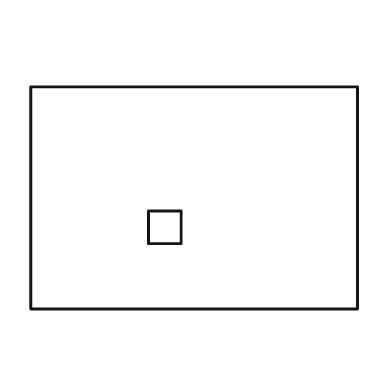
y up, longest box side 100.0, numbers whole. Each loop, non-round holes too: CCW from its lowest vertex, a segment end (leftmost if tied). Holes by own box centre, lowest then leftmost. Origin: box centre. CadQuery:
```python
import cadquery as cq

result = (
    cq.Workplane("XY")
    .moveTo(-50.0, -34.0)
    .lineTo(50.0, -34.0)
    .lineTo(50.0, 34.0)
    .lineTo(-50.0, 34.0)
    .close()
    .moveTo(-14.0, -14.0)
    .lineTo(-4.0, -14.0)
    .lineTo(-4.0, -4.0)
    .lineTo(-14.0, -4.0)
    .close()
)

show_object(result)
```